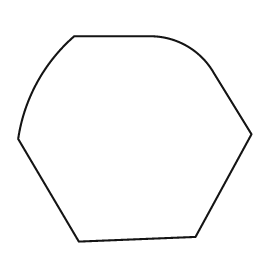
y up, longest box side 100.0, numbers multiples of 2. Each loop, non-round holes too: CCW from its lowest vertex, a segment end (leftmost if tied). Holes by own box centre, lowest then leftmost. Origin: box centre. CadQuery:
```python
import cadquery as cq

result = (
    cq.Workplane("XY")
    .moveTo(-24.0, -44.0)
    .lineTo(26.0, -42.0)
    .lineTo(50.0, 2.0)
    .lineTo(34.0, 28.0)
    .threePointArc((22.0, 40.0), (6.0, 44.0))
    .lineTo(-26.0, 44.0)
    .threePointArc((-42.0, 24.0), (-50.0, 0.0))
    .close()
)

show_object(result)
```